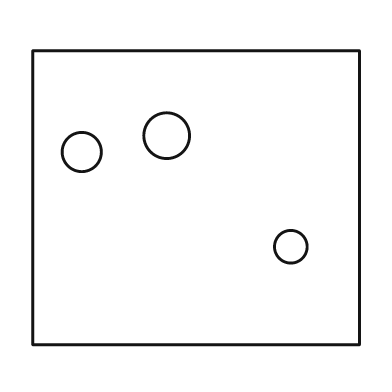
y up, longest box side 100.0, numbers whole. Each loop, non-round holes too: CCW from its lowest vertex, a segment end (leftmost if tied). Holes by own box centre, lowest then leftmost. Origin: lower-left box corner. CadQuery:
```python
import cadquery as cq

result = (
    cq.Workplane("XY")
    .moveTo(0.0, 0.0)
    .lineTo(100.0, 0.0)
    .lineTo(100.0, 90.0)
    .lineTo(0.0, 90.0)
    .close()
    .moveTo(79.0, 30.0)
    .circle(5.0)
    .moveTo(15.0, 59.0)
    .circle(6.0)
    .moveTo(41.0, 64.0)
    .circle(7.0)
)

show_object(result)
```